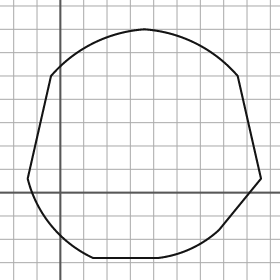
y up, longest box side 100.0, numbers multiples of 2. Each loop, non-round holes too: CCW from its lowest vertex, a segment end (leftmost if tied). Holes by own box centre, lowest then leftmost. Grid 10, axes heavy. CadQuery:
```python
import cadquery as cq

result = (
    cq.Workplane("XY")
    .moveTo(14.0, -28.0)
    .lineTo(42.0, -28.0)
    .threePointArc((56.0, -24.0), (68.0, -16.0))
    .lineTo(86.0, 6.0)
    .lineTo(76.0, 50.0)
    .threePointArc((58.0, 64.0), (36.0, 70.0))
    .threePointArc((14.0, 64.0), (-4.0, 50.0))
    .lineTo(-14.0, 6.0)
    .threePointArc((-4.0, -14.0), (14.0, -28.0))
    .close()
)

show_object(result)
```